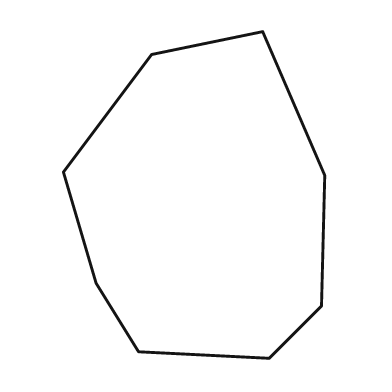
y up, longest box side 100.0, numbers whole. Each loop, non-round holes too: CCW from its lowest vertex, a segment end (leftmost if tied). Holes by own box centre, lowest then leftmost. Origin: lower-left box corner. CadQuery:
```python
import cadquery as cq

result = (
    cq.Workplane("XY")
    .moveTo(63.0, 0.0)
    .lineTo(79.0, 16.0)
    .lineTo(80.0, 56.0)
    .lineTo(61.0, 100.0)
    .lineTo(27.0, 93.0)
    .lineTo(0.0, 57.0)
    .lineTo(10.0, 23.0)
    .lineTo(23.0, 2.0)
    .close()
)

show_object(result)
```